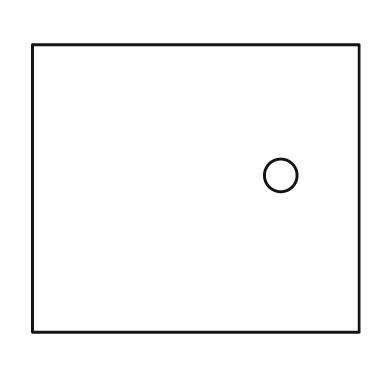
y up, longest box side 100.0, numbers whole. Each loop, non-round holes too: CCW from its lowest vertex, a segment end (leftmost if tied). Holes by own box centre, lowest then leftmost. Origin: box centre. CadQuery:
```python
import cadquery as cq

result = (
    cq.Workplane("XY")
    .moveTo(-50.0, -44.0)
    .lineTo(50.0, -44.0)
    .lineTo(50.0, 44.0)
    .lineTo(-50.0, 44.0)
    .close()
    .moveTo(26.0, 4.0)
    .circle(5.0)
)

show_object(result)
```